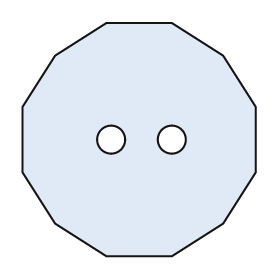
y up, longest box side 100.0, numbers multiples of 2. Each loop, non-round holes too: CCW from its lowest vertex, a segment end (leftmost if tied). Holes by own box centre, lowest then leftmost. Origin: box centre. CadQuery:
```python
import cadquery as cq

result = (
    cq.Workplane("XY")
    .moveTo(-14.0, -50.0)
    .lineTo(14.0, -50.0)
    .lineTo(36.0, -36.0)
    .lineTo(50.0, -14.0)
    .lineTo(50.0, 14.0)
    .lineTo(36.0, 36.0)
    .lineTo(14.0, 50.0)
    .lineTo(-14.0, 50.0)
    .lineTo(-36.0, 36.0)
    .lineTo(-50.0, 14.0)
    .lineTo(-50.0, -14.0)
    .lineTo(-36.0, -36.0)
    .close()
    .moveTo(-12.0, 0.0)
    .circle(6.0)
    .moveTo(14.0, 0.0)
    .circle(6.0)
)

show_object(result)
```